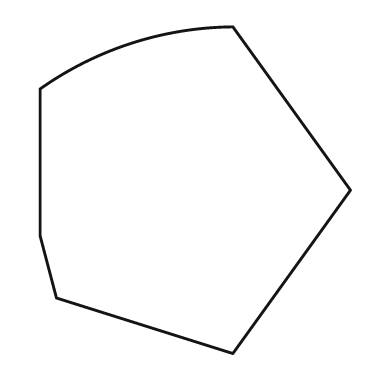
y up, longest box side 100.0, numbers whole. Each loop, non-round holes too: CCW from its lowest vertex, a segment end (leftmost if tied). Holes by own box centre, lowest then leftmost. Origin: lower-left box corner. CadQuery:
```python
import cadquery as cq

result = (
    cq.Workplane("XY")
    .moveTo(59.0, 0.0)
    .lineTo(95.0, 50.0)
    .lineTo(59.0, 100.0)
    .threePointArc((28.0, 95.0), (0.0, 81.0))
    .lineTo(0.0, 36.0)
    .lineTo(5.0, 17.0)
    .close()
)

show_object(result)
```